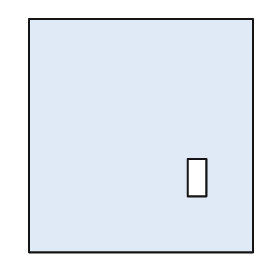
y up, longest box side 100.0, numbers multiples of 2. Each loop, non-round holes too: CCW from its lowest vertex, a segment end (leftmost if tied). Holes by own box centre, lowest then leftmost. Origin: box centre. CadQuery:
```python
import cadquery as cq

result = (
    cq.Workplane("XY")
    .moveTo(-48.0, -50.0)
    .lineTo(48.0, -50.0)
    .lineTo(48.0, 50.0)
    .lineTo(-48.0, 50.0)
    .close()
    .moveTo(20.0, -26.0)
    .lineTo(28.0, -26.0)
    .lineTo(28.0, -10.0)
    .lineTo(20.0, -10.0)
    .close()
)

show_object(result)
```